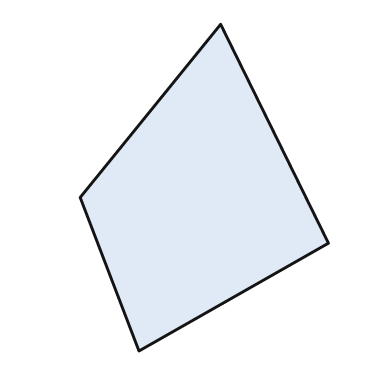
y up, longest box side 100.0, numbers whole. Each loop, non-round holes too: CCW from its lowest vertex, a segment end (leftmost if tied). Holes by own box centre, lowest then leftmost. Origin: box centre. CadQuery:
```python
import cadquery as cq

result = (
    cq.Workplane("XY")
    .moveTo(-20.0, -50.0)
    .lineTo(38.0, -17.0)
    .lineTo(5.0, 50.0)
    .lineTo(-38.0, -3.0)
    .close()
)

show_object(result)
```